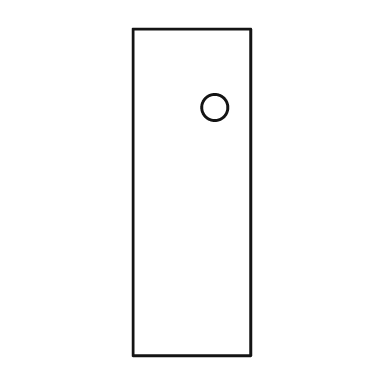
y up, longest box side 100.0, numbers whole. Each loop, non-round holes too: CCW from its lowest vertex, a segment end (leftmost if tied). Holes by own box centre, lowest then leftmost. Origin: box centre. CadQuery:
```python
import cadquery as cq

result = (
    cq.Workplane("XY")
    .moveTo(-18.0, -50.0)
    .lineTo(18.0, -50.0)
    .lineTo(18.0, 50.0)
    .lineTo(-18.0, 50.0)
    .close()
    .moveTo(7.0, 26.0)
    .circle(4.0)
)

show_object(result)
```